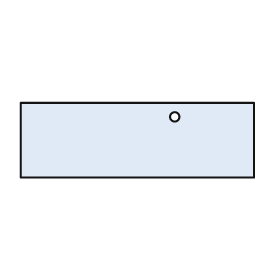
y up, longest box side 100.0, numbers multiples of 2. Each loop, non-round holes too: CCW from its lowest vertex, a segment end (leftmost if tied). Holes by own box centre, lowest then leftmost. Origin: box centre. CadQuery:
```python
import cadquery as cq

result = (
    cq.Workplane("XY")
    .moveTo(-50.0, -16.0)
    .lineTo(50.0, -16.0)
    .lineTo(50.0, 16.0)
    .lineTo(-50.0, 16.0)
    .close()
    .moveTo(16.0, 10.0)
    .circle(2.0)
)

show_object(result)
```